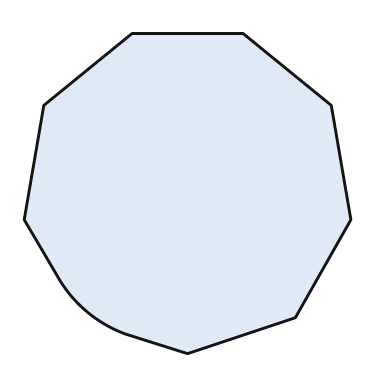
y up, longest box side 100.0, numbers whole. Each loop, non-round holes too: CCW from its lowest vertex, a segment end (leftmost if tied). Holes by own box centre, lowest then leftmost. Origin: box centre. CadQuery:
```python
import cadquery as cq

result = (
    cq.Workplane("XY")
    .moveTo(0.0, -49.0)
    .lineTo(33.0, -38.0)
    .lineTo(50.0, -8.0)
    .lineTo(44.0, 27.0)
    .lineTo(17.0, 49.0)
    .lineTo(-17.0, 49.0)
    .lineTo(-44.0, 27.0)
    .lineTo(-50.0, -8.0)
    .lineTo(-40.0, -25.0)
    .threePointArc((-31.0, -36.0), (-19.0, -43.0))
    .close()
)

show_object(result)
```